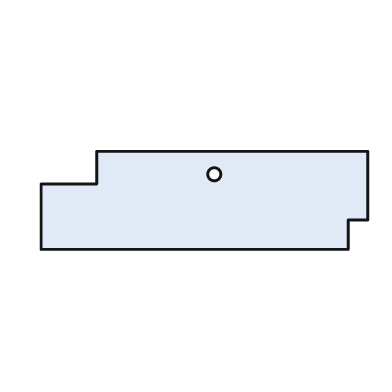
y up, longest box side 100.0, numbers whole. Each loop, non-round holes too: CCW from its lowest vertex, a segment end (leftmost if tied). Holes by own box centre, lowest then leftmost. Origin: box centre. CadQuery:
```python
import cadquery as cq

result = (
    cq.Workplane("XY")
    .moveTo(-50.0, -15.0)
    .lineTo(44.0, -15.0)
    .lineTo(44.0, -6.0)
    .lineTo(50.0, -6.0)
    .lineTo(50.0, 15.0)
    .lineTo(-33.0, 15.0)
    .lineTo(-33.0, 5.0)
    .lineTo(-50.0, 5.0)
    .close()
    .moveTo(3.0, 8.0)
    .circle(2.0)
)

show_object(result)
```